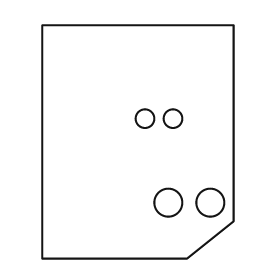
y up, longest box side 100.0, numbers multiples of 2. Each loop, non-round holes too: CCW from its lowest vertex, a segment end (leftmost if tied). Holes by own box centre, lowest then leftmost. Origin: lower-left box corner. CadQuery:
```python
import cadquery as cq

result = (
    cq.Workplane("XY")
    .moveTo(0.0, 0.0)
    .lineTo(62.0, 0.0)
    .lineTo(82.0, 16.0)
    .lineTo(82.0, 100.0)
    .lineTo(0.0, 100.0)
    .close()
    .moveTo(54.0, 24.0)
    .circle(6.0)
    .moveTo(72.0, 24.0)
    .circle(6.0)
    .moveTo(44.0, 60.0)
    .circle(4.0)
    .moveTo(56.0, 60.0)
    .circle(4.0)
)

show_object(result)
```